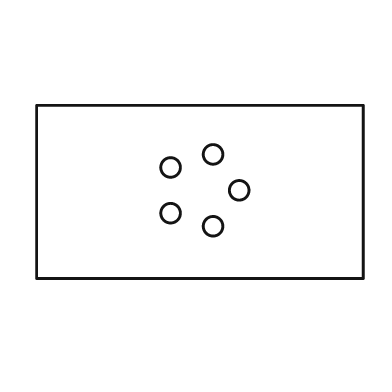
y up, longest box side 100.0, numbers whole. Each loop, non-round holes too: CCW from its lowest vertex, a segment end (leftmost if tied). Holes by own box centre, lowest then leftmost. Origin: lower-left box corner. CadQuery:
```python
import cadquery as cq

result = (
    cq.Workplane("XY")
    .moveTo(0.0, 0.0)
    .lineTo(100.0, 0.0)
    .lineTo(100.0, 53.0)
    .lineTo(0.0, 53.0)
    .close()
    .moveTo(54.0, 16.0)
    .circle(3.0)
    .moveTo(41.0, 20.0)
    .circle(3.0)
    .moveTo(62.0, 27.0)
    .circle(3.0)
    .moveTo(41.0, 34.0)
    .circle(3.0)
    .moveTo(54.0, 38.0)
    .circle(3.0)
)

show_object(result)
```